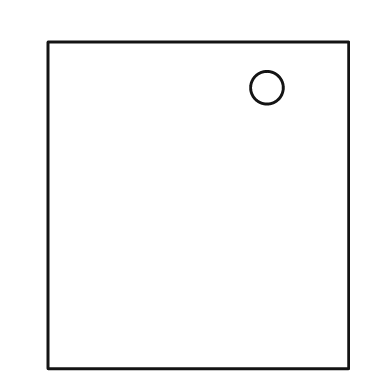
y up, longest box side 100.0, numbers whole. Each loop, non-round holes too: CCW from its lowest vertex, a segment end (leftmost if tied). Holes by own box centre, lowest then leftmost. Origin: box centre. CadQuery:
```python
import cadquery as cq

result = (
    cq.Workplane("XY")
    .moveTo(-46.0, -50.0)
    .lineTo(46.0, -50.0)
    .lineTo(46.0, 50.0)
    .lineTo(-46.0, 50.0)
    .close()
    .moveTo(21.0, 36.0)
    .circle(5.0)
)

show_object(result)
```